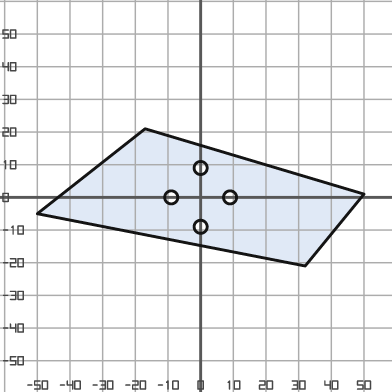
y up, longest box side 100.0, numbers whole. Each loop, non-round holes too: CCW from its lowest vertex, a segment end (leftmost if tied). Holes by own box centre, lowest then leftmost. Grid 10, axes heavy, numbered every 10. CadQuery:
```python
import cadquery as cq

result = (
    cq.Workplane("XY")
    .moveTo(32.0, -21.0)
    .lineTo(50.0, 1.0)
    .lineTo(-17.0, 21.0)
    .lineTo(-50.0, -5.0)
    .close()
    .moveTo(0.0, -9.0)
    .circle(2.0)
    .moveTo(-9.0, 0.0)
    .circle(2.0)
    .moveTo(9.0, 0.0)
    .circle(2.0)
    .moveTo(0.0, 9.0)
    .circle(2.0)
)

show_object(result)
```